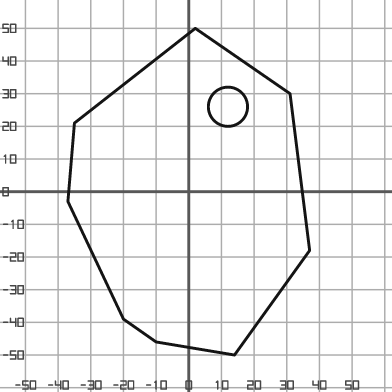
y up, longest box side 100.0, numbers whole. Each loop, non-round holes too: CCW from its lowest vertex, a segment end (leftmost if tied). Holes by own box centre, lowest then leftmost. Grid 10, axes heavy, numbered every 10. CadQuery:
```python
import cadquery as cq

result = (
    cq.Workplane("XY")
    .moveTo(14.0, -50.0)
    .lineTo(37.0, -18.0)
    .lineTo(31.0, 30.0)
    .lineTo(2.0, 50.0)
    .lineTo(-35.0, 21.0)
    .lineTo(-37.0, -3.0)
    .lineTo(-20.0, -39.0)
    .lineTo(-10.0, -46.0)
    .close()
    .moveTo(12.0, 26.0)
    .circle(6.0)
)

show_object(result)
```